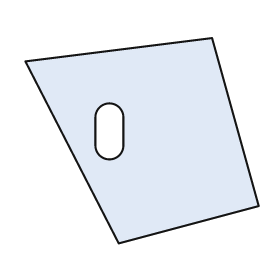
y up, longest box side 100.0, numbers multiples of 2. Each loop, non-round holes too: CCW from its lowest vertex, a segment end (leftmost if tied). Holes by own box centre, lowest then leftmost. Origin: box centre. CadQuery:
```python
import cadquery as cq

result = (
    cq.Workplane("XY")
    .moveTo(-10.0, -44.0)
    .lineTo(50.0, -28.0)
    .lineTo(30.0, 44.0)
    .lineTo(-50.0, 34.0)
    .close()
    .moveTo(-20.0, -2.0)
    .threePointArc((-14.0, -8.0), (-8.0, -2.0))
    .lineTo(-8.0, 10.0)
    .threePointArc((-14.0, 16.0), (-20.0, 10.0))
    .close()
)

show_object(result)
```